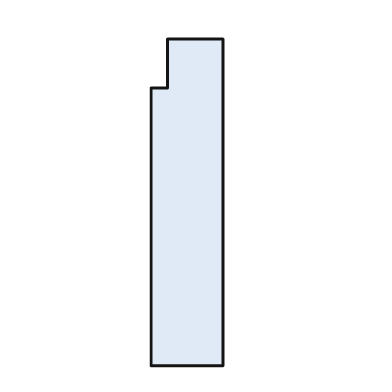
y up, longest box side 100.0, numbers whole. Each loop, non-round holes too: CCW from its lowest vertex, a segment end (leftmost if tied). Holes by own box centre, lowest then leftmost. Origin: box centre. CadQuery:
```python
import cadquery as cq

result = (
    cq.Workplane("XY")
    .moveTo(-11.0, -50.0)
    .lineTo(11.0, -50.0)
    .lineTo(11.0, 50.0)
    .lineTo(-6.0, 50.0)
    .lineTo(-6.0, 35.0)
    .lineTo(-11.0, 35.0)
    .close()
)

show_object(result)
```